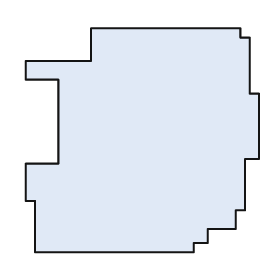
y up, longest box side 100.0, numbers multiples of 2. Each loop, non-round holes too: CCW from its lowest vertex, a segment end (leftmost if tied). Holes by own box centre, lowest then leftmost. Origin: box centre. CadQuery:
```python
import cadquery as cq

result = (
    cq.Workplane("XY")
    .moveTo(-46.0, -48.0)
    .lineTo(22.0, -48.0)
    .lineTo(22.0, -44.0)
    .lineTo(28.0, -44.0)
    .lineTo(28.0, -38.0)
    .lineTo(40.0, -38.0)
    .lineTo(40.0, -30.0)
    .lineTo(44.0, -30.0)
    .lineTo(44.0, -8.0)
    .lineTo(50.0, -8.0)
    .lineTo(50.0, 20.0)
    .lineTo(46.0, 20.0)
    .lineTo(46.0, 44.0)
    .lineTo(42.0, 44.0)
    .lineTo(42.0, 48.0)
    .lineTo(-22.0, 48.0)
    .lineTo(-22.0, 34.0)
    .lineTo(-50.0, 34.0)
    .lineTo(-50.0, 26.0)
    .lineTo(-36.0, 26.0)
    .lineTo(-36.0, -10.0)
    .lineTo(-50.0, -10.0)
    .lineTo(-50.0, -26.0)
    .lineTo(-46.0, -26.0)
    .close()
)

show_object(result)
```